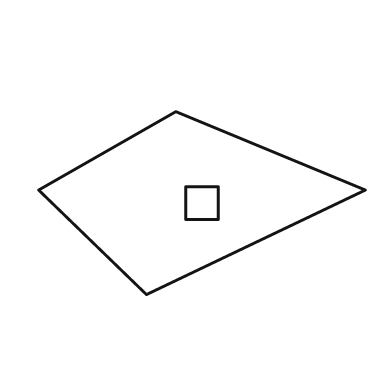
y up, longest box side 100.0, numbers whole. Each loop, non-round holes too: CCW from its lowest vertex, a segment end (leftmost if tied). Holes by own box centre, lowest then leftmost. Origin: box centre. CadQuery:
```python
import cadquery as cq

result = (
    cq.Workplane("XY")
    .moveTo(-17.0, -28.0)
    .lineTo(50.0, 4.0)
    .lineTo(-8.0, 28.0)
    .lineTo(-50.0, 4.0)
    .close()
    .moveTo(-5.0, -5.0)
    .lineTo(5.0, -5.0)
    .lineTo(5.0, 5.0)
    .lineTo(-5.0, 5.0)
    .close()
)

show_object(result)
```